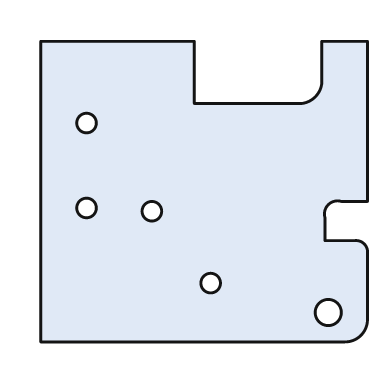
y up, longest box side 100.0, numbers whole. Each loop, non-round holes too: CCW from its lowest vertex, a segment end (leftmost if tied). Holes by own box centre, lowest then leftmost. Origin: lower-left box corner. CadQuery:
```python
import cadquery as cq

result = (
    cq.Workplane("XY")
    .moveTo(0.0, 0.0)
    .lineTo(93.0, 0.0)
    .threePointArc((98.0, 2.0), (100.0, 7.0))
    .lineTo(100.0, 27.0)
    .threePointArc((99.0, 30.0), (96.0, 31.0))
    .lineTo(87.0, 31.0)
    .lineTo(87.0, 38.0)
    .threePointArc((88.0, 42.0), (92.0, 43.0))
    .lineTo(100.0, 43.0)
    .lineTo(100.0, 92.0)
    .lineTo(86.0, 92.0)
    .lineTo(86.0, 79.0)
    .threePointArc((84.0, 75.0), (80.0, 73.0))
    .lineTo(47.0, 73.0)
    .lineTo(47.0, 92.0)
    .lineTo(0.0, 92.0)
    .close()
    .moveTo(88.0, 9.0)
    .circle(4.0)
    .moveTo(52.0, 18.0)
    .circle(3.0)
    .moveTo(34.0, 40.0)
    .circle(3.0)
    .moveTo(14.0, 41.0)
    .circle(3.0)
    .moveTo(14.0, 67.0)
    .circle(3.0)
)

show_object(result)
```